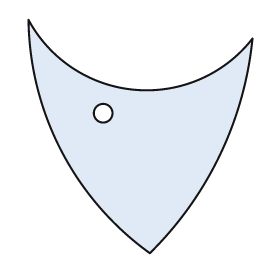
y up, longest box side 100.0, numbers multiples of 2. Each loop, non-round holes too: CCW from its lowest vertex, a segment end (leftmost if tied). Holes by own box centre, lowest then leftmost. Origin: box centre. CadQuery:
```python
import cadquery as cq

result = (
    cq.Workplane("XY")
    .moveTo(4.0, -50.0)
    .threePointArc((34.0, -8.0), (48.0, 42.0))
    .threePointArc((-2.0, 20.0), (-48.0, 50.0))
    .threePointArc((-34.0, -6.0), (4.0, -50.0))
    .close()
    .moveTo(-16.0, 10.0)
    .circle(4.0)
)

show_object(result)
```